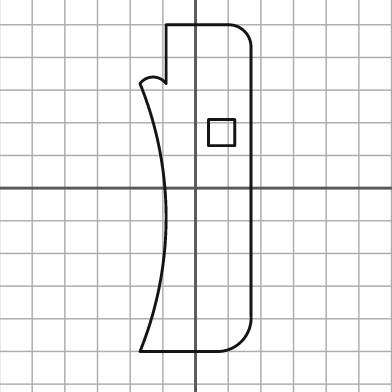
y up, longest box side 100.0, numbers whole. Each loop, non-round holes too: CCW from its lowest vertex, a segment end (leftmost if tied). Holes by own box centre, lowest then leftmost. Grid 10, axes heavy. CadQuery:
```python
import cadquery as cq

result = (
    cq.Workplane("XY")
    .moveTo(-17.0, -50.0)
    .lineTo(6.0, -50.0)
    .threePointArc((14.0, -47.0), (17.0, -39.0))
    .lineTo(17.0, 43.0)
    .threePointArc((15.0, 48.0), (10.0, 50.0))
    .lineTo(-9.0, 50.0)
    .lineTo(-9.0, 32.0)
    .threePointArc((-13.0, 34.0), (-17.0, 32.0))
    .threePointArc((-9.0, -9.0), (-17.0, -50.0))
    .close()
    .moveTo(4.0, 13.0)
    .lineTo(12.0, 13.0)
    .lineTo(12.0, 21.0)
    .lineTo(4.0, 21.0)
    .close()
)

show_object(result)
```